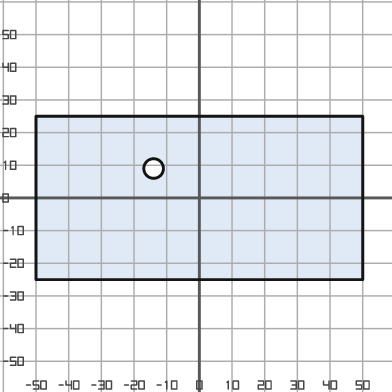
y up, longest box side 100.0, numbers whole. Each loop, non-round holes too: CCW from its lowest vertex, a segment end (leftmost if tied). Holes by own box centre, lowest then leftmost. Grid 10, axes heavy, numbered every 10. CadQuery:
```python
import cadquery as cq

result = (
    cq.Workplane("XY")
    .moveTo(-50.0, -25.0)
    .lineTo(50.0, -25.0)
    .lineTo(50.0, 25.0)
    .lineTo(-50.0, 25.0)
    .close()
    .moveTo(-14.0, 9.0)
    .circle(3.0)
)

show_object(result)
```